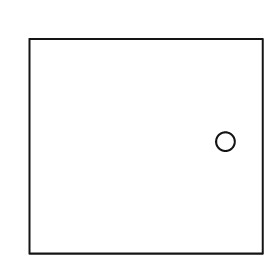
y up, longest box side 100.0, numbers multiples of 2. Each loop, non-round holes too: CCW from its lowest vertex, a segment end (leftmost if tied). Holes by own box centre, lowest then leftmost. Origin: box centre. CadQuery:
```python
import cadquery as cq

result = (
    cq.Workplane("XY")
    .moveTo(-50.0, -46.0)
    .lineTo(50.0, -46.0)
    .lineTo(50.0, 46.0)
    .lineTo(-50.0, 46.0)
    .close()
    .moveTo(34.0, 2.0)
    .circle(4.0)
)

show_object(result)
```